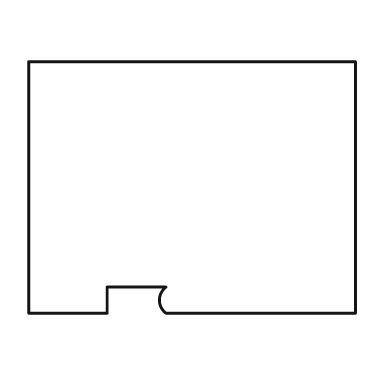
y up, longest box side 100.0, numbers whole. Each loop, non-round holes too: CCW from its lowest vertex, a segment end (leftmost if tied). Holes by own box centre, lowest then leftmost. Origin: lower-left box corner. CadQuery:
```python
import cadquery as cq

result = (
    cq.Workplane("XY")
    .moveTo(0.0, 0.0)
    .lineTo(24.0, 0.0)
    .lineTo(24.0, 8.0)
    .lineTo(42.0, 8.0)
    .threePointArc((40.0, 4.0), (42.0, 0.0))
    .lineTo(100.0, 0.0)
    .lineTo(100.0, 77.0)
    .lineTo(0.0, 77.0)
    .close()
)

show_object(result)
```